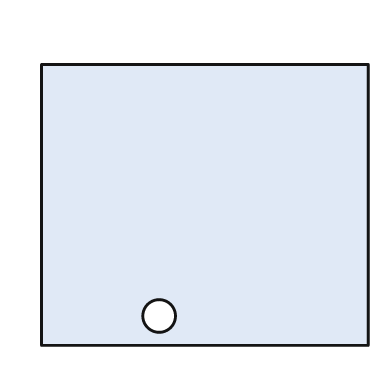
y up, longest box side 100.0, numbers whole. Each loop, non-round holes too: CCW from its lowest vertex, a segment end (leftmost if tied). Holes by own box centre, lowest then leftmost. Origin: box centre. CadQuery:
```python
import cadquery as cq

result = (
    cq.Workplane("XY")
    .moveTo(-50.0, -43.0)
    .lineTo(50.0, -43.0)
    .lineTo(50.0, 43.0)
    .lineTo(-50.0, 43.0)
    .close()
    .moveTo(-14.0, -34.0)
    .circle(5.0)
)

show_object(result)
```